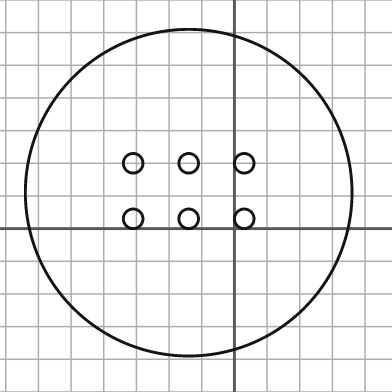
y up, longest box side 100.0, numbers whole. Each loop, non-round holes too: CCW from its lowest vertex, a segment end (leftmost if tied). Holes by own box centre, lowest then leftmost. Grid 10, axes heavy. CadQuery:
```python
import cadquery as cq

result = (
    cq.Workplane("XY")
    .moveTo(-14.0, 11.0)
    .circle(50.0)
    .moveTo(-31.0, 3.0)
    .circle(3.0)
    .moveTo(-14.0, 3.0)
    .circle(3.0)
    .moveTo(3.0, 3.0)
    .circle(3.0)
    .moveTo(-31.0, 20.0)
    .circle(3.0)
    .moveTo(-14.0, 20.0)
    .circle(3.0)
    .moveTo(3.0, 20.0)
    .circle(3.0)
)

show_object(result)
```